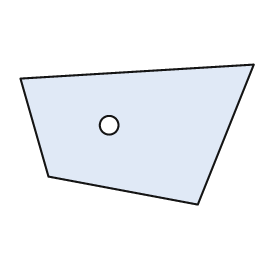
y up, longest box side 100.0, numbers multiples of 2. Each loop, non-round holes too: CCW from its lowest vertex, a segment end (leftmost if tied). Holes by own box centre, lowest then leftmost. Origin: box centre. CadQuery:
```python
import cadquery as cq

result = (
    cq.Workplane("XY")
    .moveTo(26.0, -30.0)
    .lineTo(50.0, 30.0)
    .lineTo(-50.0, 24.0)
    .lineTo(-38.0, -18.0)
    .close()
    .moveTo(-12.0, 4.0)
    .circle(4.0)
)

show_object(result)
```